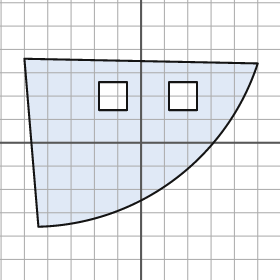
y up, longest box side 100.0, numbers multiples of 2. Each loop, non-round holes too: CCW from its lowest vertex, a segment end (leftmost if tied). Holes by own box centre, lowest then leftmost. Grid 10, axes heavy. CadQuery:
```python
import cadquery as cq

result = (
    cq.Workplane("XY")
    .moveTo(-44.0, -36.0)
    .threePointArc((14.0, -16.0), (50.0, 34.0))
    .lineTo(-50.0, 36.0)
    .close()
    .moveTo(-18.0, 14.0)
    .lineTo(-6.0, 14.0)
    .lineTo(-6.0, 26.0)
    .lineTo(-18.0, 26.0)
    .close()
    .moveTo(12.0, 14.0)
    .lineTo(24.0, 14.0)
    .lineTo(24.0, 26.0)
    .lineTo(12.0, 26.0)
    .close()
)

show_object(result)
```